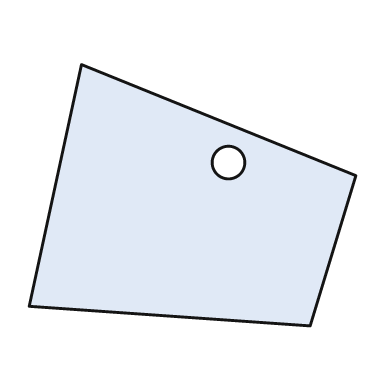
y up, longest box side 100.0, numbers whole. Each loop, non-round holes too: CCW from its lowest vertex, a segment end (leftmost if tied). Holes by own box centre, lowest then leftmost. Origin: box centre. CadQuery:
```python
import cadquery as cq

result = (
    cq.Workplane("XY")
    .moveTo(36.0, -40.0)
    .lineTo(50.0, 6.0)
    .lineTo(-34.0, 40.0)
    .lineTo(-50.0, -34.0)
    .close()
    .moveTo(11.0, 10.0)
    .circle(5.0)
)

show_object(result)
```